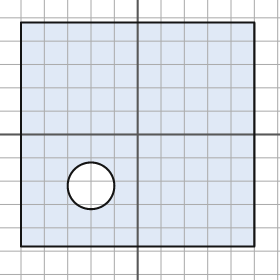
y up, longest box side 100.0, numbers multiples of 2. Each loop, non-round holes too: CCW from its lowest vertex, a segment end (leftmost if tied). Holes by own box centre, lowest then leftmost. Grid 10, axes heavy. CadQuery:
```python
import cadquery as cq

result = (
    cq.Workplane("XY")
    .moveTo(-50.0, -48.0)
    .lineTo(50.0, -48.0)
    .lineTo(50.0, 48.0)
    .lineTo(-50.0, 48.0)
    .close()
    .moveTo(-20.0, -22.0)
    .circle(10.0)
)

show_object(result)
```